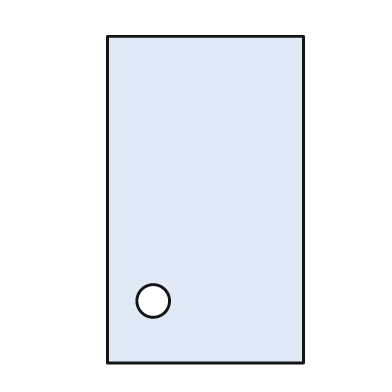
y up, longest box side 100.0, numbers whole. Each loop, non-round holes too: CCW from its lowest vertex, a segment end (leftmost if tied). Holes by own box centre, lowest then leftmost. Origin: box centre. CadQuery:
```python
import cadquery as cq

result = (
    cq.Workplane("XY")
    .moveTo(-30.0, -50.0)
    .lineTo(30.0, -50.0)
    .lineTo(30.0, 50.0)
    .lineTo(-30.0, 50.0)
    .close()
    .moveTo(-16.0, -31.0)
    .circle(5.0)
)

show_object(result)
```